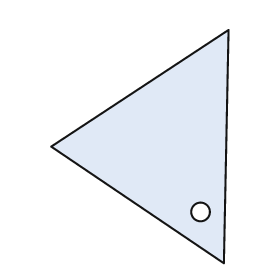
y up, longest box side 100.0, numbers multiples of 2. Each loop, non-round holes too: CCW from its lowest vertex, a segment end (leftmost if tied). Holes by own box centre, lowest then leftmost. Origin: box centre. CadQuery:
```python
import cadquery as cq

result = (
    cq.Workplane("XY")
    .moveTo(36.0, -50.0)
    .lineTo(38.0, 50.0)
    .lineTo(-38.0, 0.0)
    .close()
    .moveTo(26.0, -28.0)
    .circle(4.0)
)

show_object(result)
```